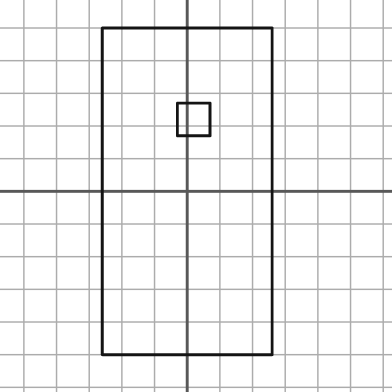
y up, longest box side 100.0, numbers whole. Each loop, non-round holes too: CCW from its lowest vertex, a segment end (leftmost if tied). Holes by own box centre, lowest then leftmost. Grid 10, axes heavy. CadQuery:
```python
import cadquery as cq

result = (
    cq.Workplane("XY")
    .moveTo(-26.0, -50.0)
    .lineTo(26.0, -50.0)
    .lineTo(26.0, 50.0)
    .lineTo(-26.0, 50.0)
    .close()
    .moveTo(-3.0, 17.0)
    .lineTo(7.0, 17.0)
    .lineTo(7.0, 27.0)
    .lineTo(-3.0, 27.0)
    .close()
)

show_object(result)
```